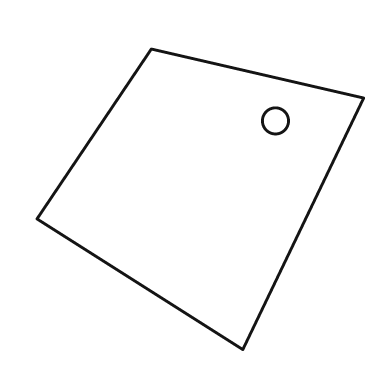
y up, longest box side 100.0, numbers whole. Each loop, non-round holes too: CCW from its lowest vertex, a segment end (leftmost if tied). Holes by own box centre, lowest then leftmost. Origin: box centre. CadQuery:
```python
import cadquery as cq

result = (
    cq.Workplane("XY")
    .moveTo(13.0, -46.0)
    .lineTo(50.0, 31.0)
    .lineTo(-15.0, 46.0)
    .lineTo(-50.0, -6.0)
    .close()
    .moveTo(23.0, 24.0)
    .circle(4.0)
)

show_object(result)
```